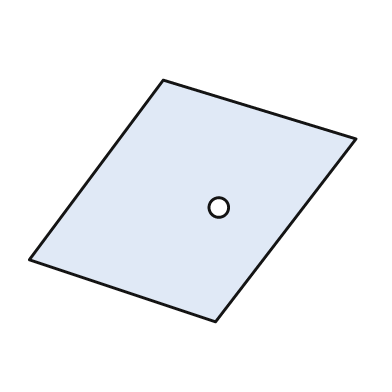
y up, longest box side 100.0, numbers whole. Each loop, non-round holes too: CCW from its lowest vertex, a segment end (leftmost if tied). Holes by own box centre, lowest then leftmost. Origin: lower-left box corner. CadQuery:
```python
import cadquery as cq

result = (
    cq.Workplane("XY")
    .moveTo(57.0, 0.0)
    .lineTo(100.0, 56.0)
    .lineTo(41.0, 74.0)
    .lineTo(0.0, 19.0)
    .close()
    .moveTo(58.0, 35.0)
    .circle(3.0)
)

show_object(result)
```